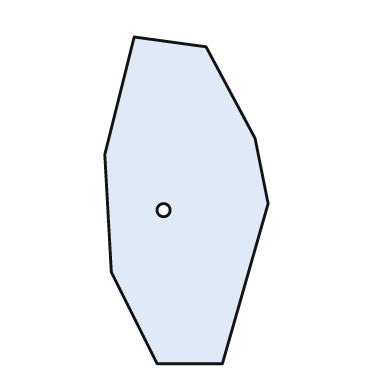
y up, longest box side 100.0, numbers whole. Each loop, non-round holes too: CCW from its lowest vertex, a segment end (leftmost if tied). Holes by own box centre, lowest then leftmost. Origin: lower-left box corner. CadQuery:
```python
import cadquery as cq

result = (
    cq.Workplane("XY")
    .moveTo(16.0, 0.0)
    .lineTo(36.0, 0.0)
    .lineTo(50.0, 49.0)
    .lineTo(46.0, 69.0)
    .lineTo(31.0, 97.0)
    .lineTo(9.0, 100.0)
    .lineTo(0.0, 64.0)
    .lineTo(2.0, 28.0)
    .close()
    .moveTo(18.0, 47.0)
    .circle(2.0)
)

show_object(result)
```